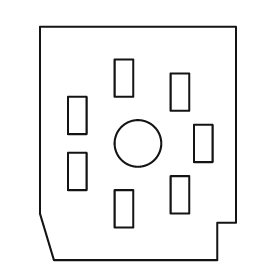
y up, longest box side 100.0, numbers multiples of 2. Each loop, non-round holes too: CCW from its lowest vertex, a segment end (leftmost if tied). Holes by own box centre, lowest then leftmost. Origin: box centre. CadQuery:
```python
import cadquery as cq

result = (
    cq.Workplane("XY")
    .moveTo(-36.0, -50.0)
    .lineTo(34.0, -50.0)
    .lineTo(34.0, -34.0)
    .lineTo(42.0, -34.0)
    .lineTo(42.0, 50.0)
    .lineTo(-42.0, 50.0)
    .lineTo(-42.0, -30.0)
    .close()
    .moveTo(-10.0, -36.0)
    .lineTo(-2.0, -36.0)
    .lineTo(-2.0, -20.0)
    .lineTo(-10.0, -20.0)
    .close()
    .moveTo(14.0, -30.0)
    .lineTo(22.0, -30.0)
    .lineTo(22.0, -14.0)
    .lineTo(14.0, -14.0)
    .close()
    .moveTo(-30.0, -20.0)
    .lineTo(-22.0, -20.0)
    .lineTo(-22.0, -4.0)
    .lineTo(-30.0, -4.0)
    .close()
    .moveTo(0.0, 0.0)
    .circle(10.0)
    .moveTo(24.0, -8.0)
    .lineTo(32.0, -8.0)
    .lineTo(32.0, 8.0)
    .lineTo(24.0, 8.0)
    .close()
    .moveTo(-30.0, 4.0)
    .lineTo(-22.0, 4.0)
    .lineTo(-22.0, 20.0)
    .lineTo(-30.0, 20.0)
    .close()
    .moveTo(14.0, 14.0)
    .lineTo(22.0, 14.0)
    .lineTo(22.0, 30.0)
    .lineTo(14.0, 30.0)
    .close()
    .moveTo(-10.0, 20.0)
    .lineTo(-2.0, 20.0)
    .lineTo(-2.0, 36.0)
    .lineTo(-10.0, 36.0)
    .close()
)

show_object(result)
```